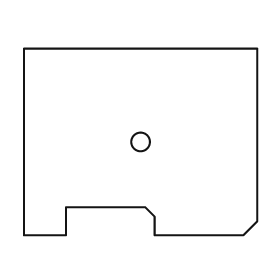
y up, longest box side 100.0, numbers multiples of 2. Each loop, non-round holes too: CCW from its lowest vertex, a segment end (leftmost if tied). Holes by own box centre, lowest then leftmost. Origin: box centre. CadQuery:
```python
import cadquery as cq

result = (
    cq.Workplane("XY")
    .moveTo(-50.0, -40.0)
    .lineTo(-32.0, -40.0)
    .lineTo(-32.0, -28.0)
    .lineTo(2.0, -28.0)
    .lineTo(6.0, -32.0)
    .lineTo(6.0, -40.0)
    .lineTo(44.0, -40.0)
    .lineTo(50.0, -34.0)
    .lineTo(50.0, 40.0)
    .lineTo(-50.0, 40.0)
    .close()
    .moveTo(0.0, 0.0)
    .circle(4.0)
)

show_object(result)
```